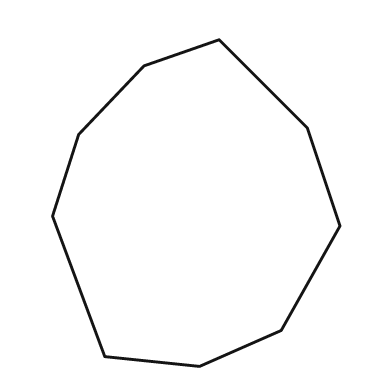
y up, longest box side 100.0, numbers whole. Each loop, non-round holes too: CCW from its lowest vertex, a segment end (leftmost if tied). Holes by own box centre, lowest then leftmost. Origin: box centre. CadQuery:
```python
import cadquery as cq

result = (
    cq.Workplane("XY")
    .moveTo(1.0, -50.0)
    .lineTo(26.0, -39.0)
    .lineTo(44.0, -7.0)
    .lineTo(34.0, 23.0)
    .lineTo(7.0, 50.0)
    .lineTo(-16.0, 42.0)
    .lineTo(-36.0, 21.0)
    .lineTo(-44.0, -4.0)
    .lineTo(-28.0, -47.0)
    .close()
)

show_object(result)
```